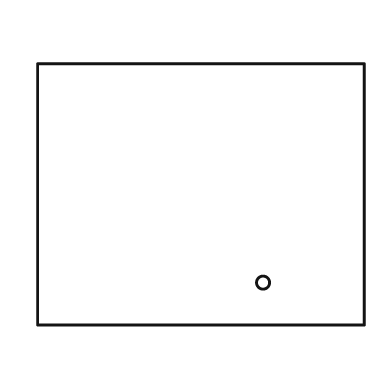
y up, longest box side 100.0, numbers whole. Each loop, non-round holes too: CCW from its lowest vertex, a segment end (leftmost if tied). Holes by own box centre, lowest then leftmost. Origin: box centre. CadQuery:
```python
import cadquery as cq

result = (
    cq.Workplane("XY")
    .moveTo(-50.0, -40.0)
    .lineTo(50.0, -40.0)
    .lineTo(50.0, 40.0)
    .lineTo(-50.0, 40.0)
    .close()
    .moveTo(19.0, -27.0)
    .circle(2.0)
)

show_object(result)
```